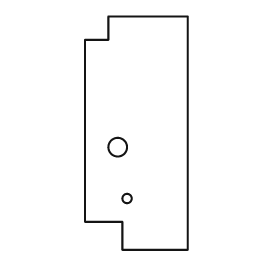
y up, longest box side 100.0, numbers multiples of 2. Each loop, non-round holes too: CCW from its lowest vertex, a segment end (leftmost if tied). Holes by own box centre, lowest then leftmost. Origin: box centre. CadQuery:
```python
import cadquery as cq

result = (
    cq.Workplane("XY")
    .moveTo(-6.0, -50.0)
    .lineTo(22.0, -50.0)
    .lineTo(22.0, 50.0)
    .lineTo(-12.0, 50.0)
    .lineTo(-12.0, 40.0)
    .lineTo(-22.0, 40.0)
    .lineTo(-22.0, -38.0)
    .lineTo(-6.0, -38.0)
    .close()
    .moveTo(-4.0, -28.0)
    .circle(2.0)
    .moveTo(-8.0, -6.0)
    .circle(4.0)
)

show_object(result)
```